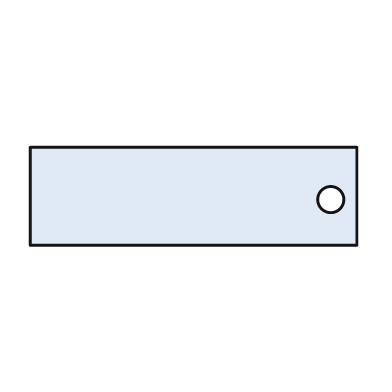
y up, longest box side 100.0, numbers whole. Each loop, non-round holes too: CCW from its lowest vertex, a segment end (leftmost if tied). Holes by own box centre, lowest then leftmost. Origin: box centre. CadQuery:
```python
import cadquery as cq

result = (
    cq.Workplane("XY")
    .moveTo(-50.0, -15.0)
    .lineTo(50.0, -15.0)
    .lineTo(50.0, 15.0)
    .lineTo(-50.0, 15.0)
    .close()
    .moveTo(42.0, -1.0)
    .circle(4.0)
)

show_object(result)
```